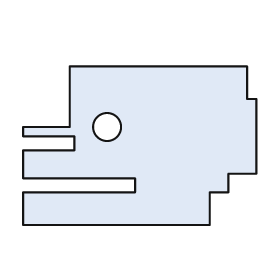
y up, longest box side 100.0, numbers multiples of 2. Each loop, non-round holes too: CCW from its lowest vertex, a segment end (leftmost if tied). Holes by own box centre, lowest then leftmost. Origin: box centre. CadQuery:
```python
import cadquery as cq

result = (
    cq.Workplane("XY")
    .moveTo(-50.0, -34.0)
    .lineTo(30.0, -34.0)
    .lineTo(30.0, -20.0)
    .lineTo(38.0, -20.0)
    .lineTo(38.0, -12.0)
    .lineTo(50.0, -12.0)
    .lineTo(50.0, 20.0)
    .lineTo(46.0, 20.0)
    .lineTo(46.0, 34.0)
    .lineTo(-30.0, 34.0)
    .lineTo(-30.0, 8.0)
    .lineTo(-50.0, 8.0)
    .lineTo(-50.0, 4.0)
    .lineTo(-28.0, 4.0)
    .lineTo(-28.0, -2.0)
    .lineTo(-50.0, -2.0)
    .lineTo(-50.0, -14.0)
    .lineTo(-2.0, -14.0)
    .lineTo(-2.0, -20.0)
    .lineTo(-50.0, -20.0)
    .close()
    .moveTo(-14.0, 8.0)
    .circle(6.0)
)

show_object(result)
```